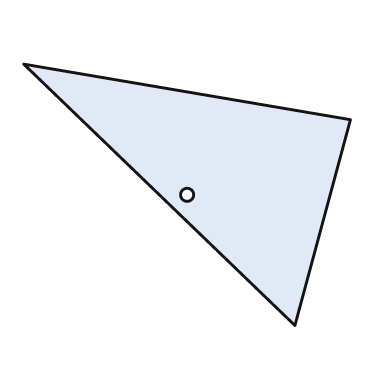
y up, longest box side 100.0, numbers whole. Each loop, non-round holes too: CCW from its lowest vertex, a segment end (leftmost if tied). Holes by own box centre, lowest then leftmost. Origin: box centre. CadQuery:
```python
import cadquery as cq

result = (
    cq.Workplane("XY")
    .moveTo(33.0, -40.0)
    .lineTo(50.0, 23.0)
    .lineTo(-50.0, 40.0)
    .close()
    .moveTo(0.0, 0.0)
    .circle(2.0)
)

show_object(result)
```